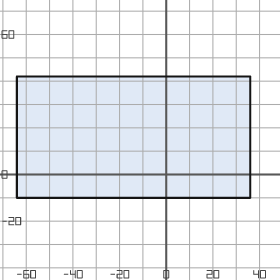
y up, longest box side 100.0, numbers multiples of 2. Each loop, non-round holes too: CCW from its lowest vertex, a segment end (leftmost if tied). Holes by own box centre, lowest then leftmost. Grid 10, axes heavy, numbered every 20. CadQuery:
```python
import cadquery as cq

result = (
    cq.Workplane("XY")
    .moveTo(-64.0, -10.0)
    .lineTo(36.0, -10.0)
    .lineTo(36.0, 42.0)
    .lineTo(-64.0, 42.0)
    .close()
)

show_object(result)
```